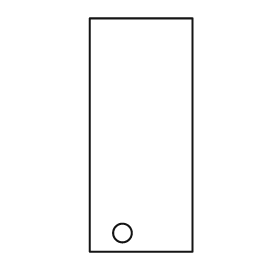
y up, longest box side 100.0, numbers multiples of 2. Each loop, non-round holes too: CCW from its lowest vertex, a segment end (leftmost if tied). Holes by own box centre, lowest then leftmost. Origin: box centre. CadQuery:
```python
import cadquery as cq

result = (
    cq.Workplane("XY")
    .moveTo(-22.0, -50.0)
    .lineTo(22.0, -50.0)
    .lineTo(22.0, 50.0)
    .lineTo(-22.0, 50.0)
    .close()
    .moveTo(-8.0, -42.0)
    .circle(4.0)
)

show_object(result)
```